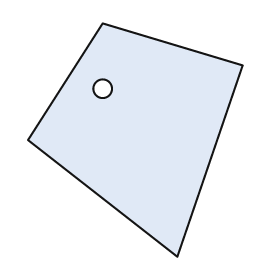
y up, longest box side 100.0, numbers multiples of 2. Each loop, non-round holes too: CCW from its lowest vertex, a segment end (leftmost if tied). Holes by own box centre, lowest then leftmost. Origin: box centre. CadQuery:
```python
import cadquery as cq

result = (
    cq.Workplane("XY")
    .moveTo(18.0, -50.0)
    .lineTo(46.0, 32.0)
    .lineTo(-14.0, 50.0)
    .lineTo(-46.0, 0.0)
    .close()
    .moveTo(-14.0, 22.0)
    .circle(4.0)
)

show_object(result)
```